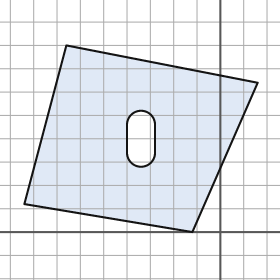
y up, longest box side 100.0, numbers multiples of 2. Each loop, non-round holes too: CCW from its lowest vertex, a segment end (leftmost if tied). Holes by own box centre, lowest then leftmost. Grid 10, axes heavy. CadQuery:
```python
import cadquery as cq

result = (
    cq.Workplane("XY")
    .moveTo(-12.0, 0.0)
    .lineTo(16.0, 64.0)
    .lineTo(-66.0, 80.0)
    .lineTo(-84.0, 12.0)
    .close()
    .moveTo(-40.0, 34.0)
    .threePointArc((-34.0, 28.0), (-28.0, 34.0))
    .lineTo(-28.0, 46.0)
    .threePointArc((-34.0, 52.0), (-40.0, 46.0))
    .close()
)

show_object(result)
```